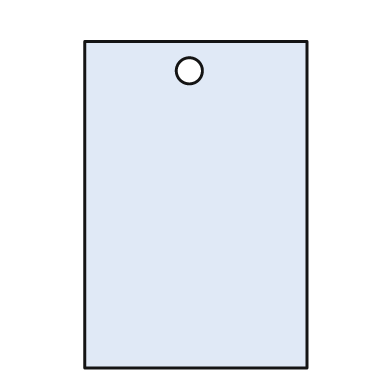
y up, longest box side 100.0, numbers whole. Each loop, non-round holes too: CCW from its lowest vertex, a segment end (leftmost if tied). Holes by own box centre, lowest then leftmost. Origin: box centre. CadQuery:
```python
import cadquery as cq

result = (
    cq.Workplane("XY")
    .moveTo(-34.0, -50.0)
    .lineTo(34.0, -50.0)
    .lineTo(34.0, 50.0)
    .lineTo(-34.0, 50.0)
    .close()
    .moveTo(-2.0, 41.0)
    .circle(4.0)
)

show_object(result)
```